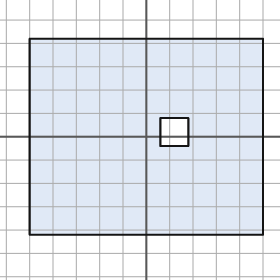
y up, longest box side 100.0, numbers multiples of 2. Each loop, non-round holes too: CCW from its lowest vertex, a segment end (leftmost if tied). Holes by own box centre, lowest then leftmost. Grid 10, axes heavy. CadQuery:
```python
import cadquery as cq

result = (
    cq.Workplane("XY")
    .moveTo(-50.0, -42.0)
    .lineTo(50.0, -42.0)
    .lineTo(50.0, 42.0)
    .lineTo(-50.0, 42.0)
    .close()
    .moveTo(6.0, -4.0)
    .lineTo(18.0, -4.0)
    .lineTo(18.0, 8.0)
    .lineTo(6.0, 8.0)
    .close()
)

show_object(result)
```